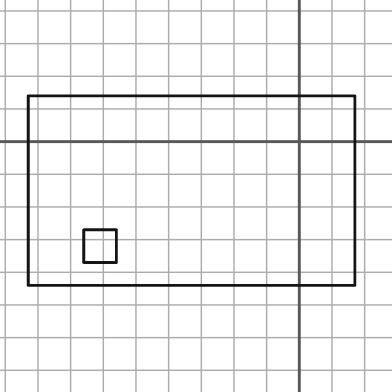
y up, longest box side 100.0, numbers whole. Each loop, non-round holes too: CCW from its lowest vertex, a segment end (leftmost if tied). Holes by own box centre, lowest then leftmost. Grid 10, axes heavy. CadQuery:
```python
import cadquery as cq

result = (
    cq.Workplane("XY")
    .moveTo(-83.0, -44.0)
    .lineTo(17.0, -44.0)
    .lineTo(17.0, 14.0)
    .lineTo(-83.0, 14.0)
    .close()
    .moveTo(-66.0, -37.0)
    .lineTo(-56.0, -37.0)
    .lineTo(-56.0, -27.0)
    .lineTo(-66.0, -27.0)
    .close()
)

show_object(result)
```